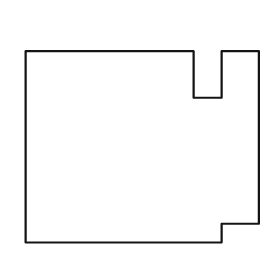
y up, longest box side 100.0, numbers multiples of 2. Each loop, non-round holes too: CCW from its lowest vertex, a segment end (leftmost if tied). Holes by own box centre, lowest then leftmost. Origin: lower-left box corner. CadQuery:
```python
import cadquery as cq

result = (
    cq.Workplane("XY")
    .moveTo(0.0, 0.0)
    .lineTo(84.0, 0.0)
    .lineTo(84.0, 8.0)
    .lineTo(100.0, 8.0)
    .lineTo(100.0, 82.0)
    .lineTo(84.0, 82.0)
    .lineTo(84.0, 62.0)
    .lineTo(72.0, 62.0)
    .lineTo(72.0, 82.0)
    .lineTo(0.0, 82.0)
    .close()
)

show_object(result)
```